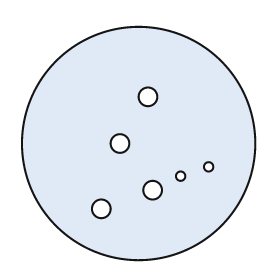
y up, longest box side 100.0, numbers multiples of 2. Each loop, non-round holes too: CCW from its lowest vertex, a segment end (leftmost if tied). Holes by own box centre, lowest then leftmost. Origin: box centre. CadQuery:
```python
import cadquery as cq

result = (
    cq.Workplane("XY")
    .moveTo(0.0, 0.0)
    .circle(50.0)
    .moveTo(-16.0, -28.0)
    .circle(4.0)
    .moveTo(6.0, -20.0)
    .circle(4.0)
    .moveTo(18.0, -14.0)
    .circle(2.0)
    .moveTo(30.0, -10.0)
    .circle(2.0)
    .moveTo(-8.0, 0.0)
    .circle(4.0)
    .moveTo(4.0, 20.0)
    .circle(4.0)
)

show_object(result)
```